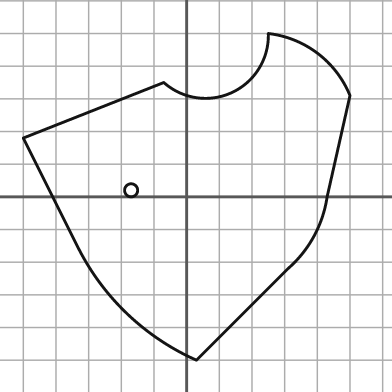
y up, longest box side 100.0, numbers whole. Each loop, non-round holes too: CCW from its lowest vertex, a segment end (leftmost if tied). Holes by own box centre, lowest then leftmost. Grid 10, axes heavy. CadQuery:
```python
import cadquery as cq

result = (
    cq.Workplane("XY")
    .moveTo(3.0, -50.0)
    .lineTo(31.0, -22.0)
    .threePointArc((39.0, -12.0), (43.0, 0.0))
    .lineTo(50.0, 31.0)
    .threePointArc((40.0, 44.0), (25.0, 50.0))
    .threePointArc((14.0, 32.0), (-7.0, 35.0))
    .lineTo(-50.0, 18.0)
    .lineTo(-33.0, -16.0)
    .threePointArc((-18.0, -36.0), (3.0, -50.0))
    .close()
    .moveTo(-17.0, 2.0)
    .circle(2.0)
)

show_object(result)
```